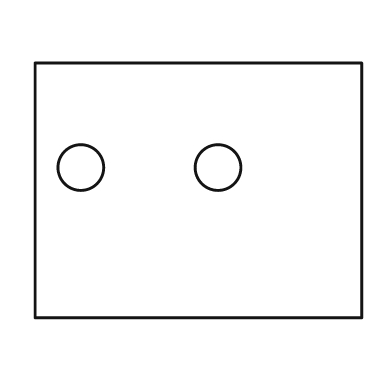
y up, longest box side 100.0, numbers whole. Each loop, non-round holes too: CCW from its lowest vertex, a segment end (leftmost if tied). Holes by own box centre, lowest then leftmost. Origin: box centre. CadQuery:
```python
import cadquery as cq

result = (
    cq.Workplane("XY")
    .moveTo(-50.0, -39.0)
    .lineTo(50.0, -39.0)
    .lineTo(50.0, 39.0)
    .lineTo(-50.0, 39.0)
    .close()
    .moveTo(-36.0, 7.0)
    .circle(7.0)
    .moveTo(6.0, 7.0)
    .circle(7.0)
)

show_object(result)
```